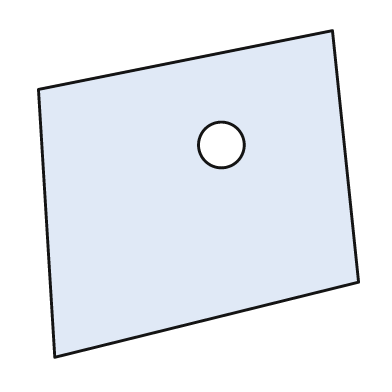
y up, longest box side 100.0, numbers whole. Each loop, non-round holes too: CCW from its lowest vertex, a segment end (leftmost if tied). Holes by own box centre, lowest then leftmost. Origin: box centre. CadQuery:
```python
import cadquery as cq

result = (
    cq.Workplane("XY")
    .moveTo(-44.0, -50.0)
    .lineTo(49.0, -27.0)
    .lineTo(41.0, 50.0)
    .lineTo(-49.0, 32.0)
    .close()
    .moveTo(7.0, 15.0)
    .circle(7.0)
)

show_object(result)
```